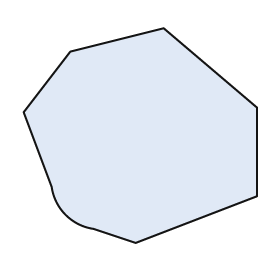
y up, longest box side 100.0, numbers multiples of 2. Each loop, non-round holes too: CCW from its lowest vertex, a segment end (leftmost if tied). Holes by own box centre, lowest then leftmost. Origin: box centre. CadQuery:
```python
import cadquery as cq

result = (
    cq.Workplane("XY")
    .moveTo(-2.0, -46.0)
    .lineTo(50.0, -26.0)
    .lineTo(50.0, 12.0)
    .lineTo(10.0, 46.0)
    .lineTo(-30.0, 36.0)
    .lineTo(-50.0, 10.0)
    .lineTo(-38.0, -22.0)
    .threePointArc((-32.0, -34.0), (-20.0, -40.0))
    .close()
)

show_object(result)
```